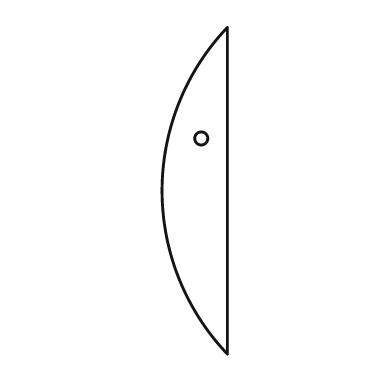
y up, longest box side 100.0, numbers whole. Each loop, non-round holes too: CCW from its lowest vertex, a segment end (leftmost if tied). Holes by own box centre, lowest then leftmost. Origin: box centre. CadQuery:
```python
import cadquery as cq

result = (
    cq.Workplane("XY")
    .moveTo(10.0, -50.0)
    .lineTo(10.0, 50.0)
    .threePointArc((-10.0, 0.0), (10.0, -50.0))
    .close()
    .moveTo(2.0, 16.0)
    .circle(2.0)
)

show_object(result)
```